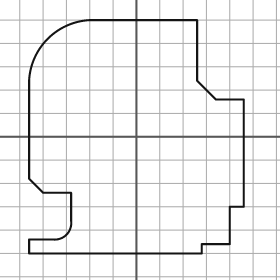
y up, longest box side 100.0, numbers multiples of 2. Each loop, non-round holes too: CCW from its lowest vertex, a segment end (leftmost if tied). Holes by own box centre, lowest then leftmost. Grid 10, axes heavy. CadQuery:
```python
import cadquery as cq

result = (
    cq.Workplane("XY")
    .moveTo(-46.0, -50.0)
    .lineTo(28.0, -50.0)
    .lineTo(28.0, -46.0)
    .lineTo(40.0, -46.0)
    .lineTo(40.0, -30.0)
    .lineTo(46.0, -30.0)
    .lineTo(46.0, 16.0)
    .lineTo(34.0, 16.0)
    .lineTo(26.0, 24.0)
    .lineTo(26.0, 50.0)
    .lineTo(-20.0, 50.0)
    .threePointArc((-38.0, 42.0), (-46.0, 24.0))
    .lineTo(-46.0, -18.0)
    .lineTo(-40.0, -24.0)
    .lineTo(-28.0, -24.0)
    .lineTo(-28.0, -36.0)
    .threePointArc((-30.0, -42.0), (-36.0, -44.0))
    .lineTo(-46.0, -44.0)
    .close()
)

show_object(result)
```